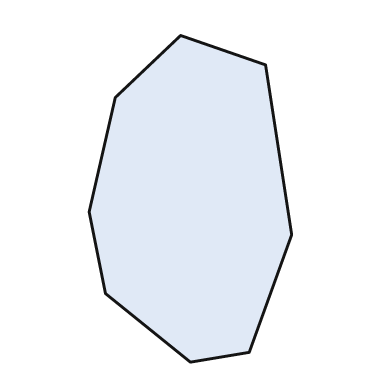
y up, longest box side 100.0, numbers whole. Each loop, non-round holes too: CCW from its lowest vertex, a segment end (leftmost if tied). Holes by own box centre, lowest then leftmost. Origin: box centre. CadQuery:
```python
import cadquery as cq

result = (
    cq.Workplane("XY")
    .moveTo(0.0, -50.0)
    .lineTo(18.0, -47.0)
    .lineTo(31.0, -11.0)
    .lineTo(23.0, 41.0)
    .lineTo(-3.0, 50.0)
    .lineTo(-23.0, 31.0)
    .lineTo(-31.0, -4.0)
    .lineTo(-26.0, -29.0)
    .close()
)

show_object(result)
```